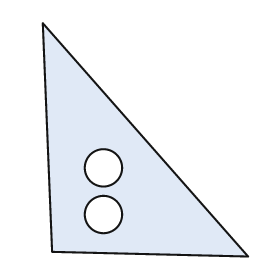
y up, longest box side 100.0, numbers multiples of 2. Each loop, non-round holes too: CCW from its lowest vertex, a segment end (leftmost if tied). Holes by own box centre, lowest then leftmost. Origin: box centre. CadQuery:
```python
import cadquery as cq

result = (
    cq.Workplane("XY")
    .moveTo(44.0, -50.0)
    .lineTo(-44.0, 50.0)
    .lineTo(-40.0, -48.0)
    .close()
    .moveTo(-18.0, -32.0)
    .circle(8.0)
    .moveTo(-18.0, -12.0)
    .circle(8.0)
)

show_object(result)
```